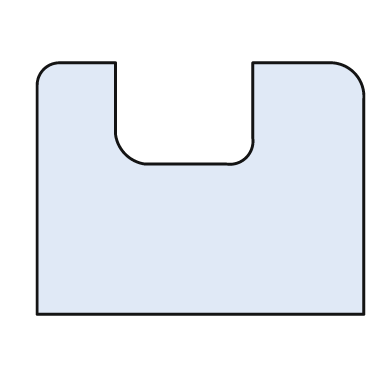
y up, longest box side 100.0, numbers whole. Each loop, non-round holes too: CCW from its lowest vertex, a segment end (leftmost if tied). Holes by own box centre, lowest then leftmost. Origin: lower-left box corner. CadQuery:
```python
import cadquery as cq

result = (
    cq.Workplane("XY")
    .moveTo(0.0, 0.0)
    .lineTo(100.0, 0.0)
    .lineTo(100.0, 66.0)
    .threePointArc((97.0, 74.0), (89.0, 77.0))
    .lineTo(66.0, 77.0)
    .lineTo(66.0, 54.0)
    .threePointArc((64.0, 48.0), (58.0, 46.0))
    .lineTo(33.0, 46.0)
    .threePointArc((27.0, 49.0), (24.0, 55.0))
    .lineTo(24.0, 77.0)
    .lineTo(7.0, 77.0)
    .threePointArc((2.0, 75.0), (0.0, 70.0))
    .close()
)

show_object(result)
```